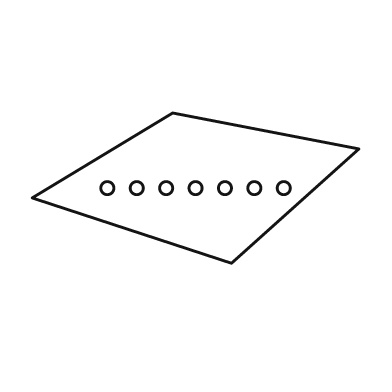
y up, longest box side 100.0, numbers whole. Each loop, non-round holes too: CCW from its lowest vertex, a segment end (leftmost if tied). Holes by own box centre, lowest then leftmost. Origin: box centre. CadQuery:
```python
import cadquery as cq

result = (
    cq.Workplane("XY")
    .moveTo(11.0, -23.0)
    .lineTo(50.0, 12.0)
    .lineTo(-7.0, 23.0)
    .lineTo(-50.0, -3.0)
    .close()
    .moveTo(-27.0, 0.0)
    .circle(2.0)
    .moveTo(-18.0, 0.0)
    .circle(2.0)
    .moveTo(-9.0, 0.0)
    .circle(2.0)
    .moveTo(0.0, 0.0)
    .circle(2.0)
    .moveTo(9.0, 0.0)
    .circle(2.0)
    .moveTo(18.0, 0.0)
    .circle(2.0)
    .moveTo(27.0, 0.0)
    .circle(2.0)
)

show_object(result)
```